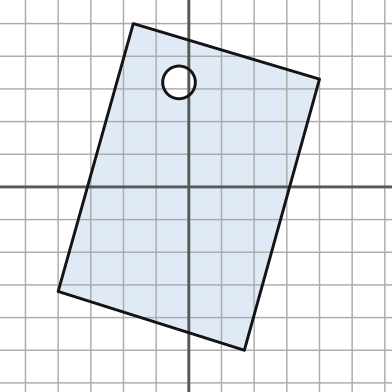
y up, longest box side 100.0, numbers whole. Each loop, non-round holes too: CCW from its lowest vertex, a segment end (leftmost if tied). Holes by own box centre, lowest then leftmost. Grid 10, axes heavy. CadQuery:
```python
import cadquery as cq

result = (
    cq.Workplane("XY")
    .moveTo(17.0, -50.0)
    .lineTo(40.0, 33.0)
    .lineTo(-17.0, 50.0)
    .lineTo(-40.0, -32.0)
    .close()
    .moveTo(-3.0, 32.0)
    .circle(5.0)
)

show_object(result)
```